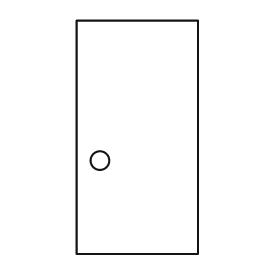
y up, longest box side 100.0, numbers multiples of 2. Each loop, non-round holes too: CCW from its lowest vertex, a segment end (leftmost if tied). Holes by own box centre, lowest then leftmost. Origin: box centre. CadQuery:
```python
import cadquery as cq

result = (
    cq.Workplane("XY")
    .moveTo(-26.0, -50.0)
    .lineTo(26.0, -50.0)
    .lineTo(26.0, 50.0)
    .lineTo(-26.0, 50.0)
    .close()
    .moveTo(-16.0, -10.0)
    .circle(4.0)
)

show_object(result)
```